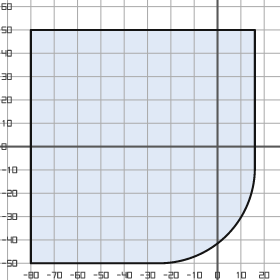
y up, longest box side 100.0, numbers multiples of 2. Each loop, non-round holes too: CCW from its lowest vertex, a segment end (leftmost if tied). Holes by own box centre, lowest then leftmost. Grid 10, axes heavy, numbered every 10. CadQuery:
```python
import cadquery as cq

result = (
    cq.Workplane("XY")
    .moveTo(-80.0, -50.0)
    .lineTo(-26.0, -50.0)
    .threePointArc((4.0, -38.0), (16.0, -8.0))
    .lineTo(16.0, 50.0)
    .lineTo(-80.0, 50.0)
    .close()
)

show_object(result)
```